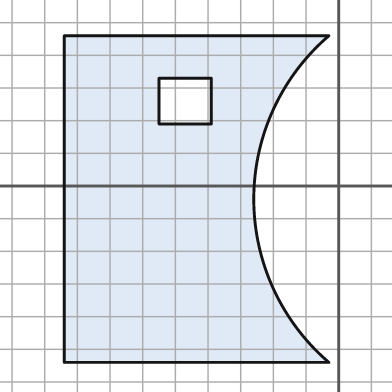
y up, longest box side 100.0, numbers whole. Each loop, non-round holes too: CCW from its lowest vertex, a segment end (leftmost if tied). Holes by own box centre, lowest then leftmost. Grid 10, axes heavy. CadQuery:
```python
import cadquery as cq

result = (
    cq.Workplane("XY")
    .moveTo(-84.0, -54.0)
    .lineTo(-3.0, -54.0)
    .threePointArc((-26.0, -4.0), (-3.0, 46.0))
    .lineTo(-84.0, 46.0)
    .close()
    .moveTo(-55.0, 19.0)
    .lineTo(-39.0, 19.0)
    .lineTo(-39.0, 33.0)
    .lineTo(-55.0, 33.0)
    .close()
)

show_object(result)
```